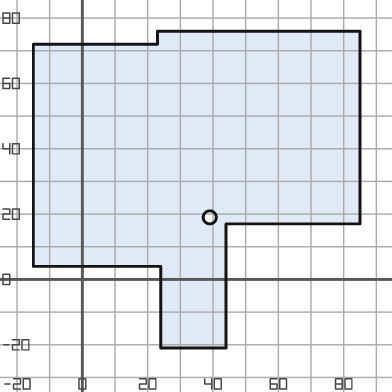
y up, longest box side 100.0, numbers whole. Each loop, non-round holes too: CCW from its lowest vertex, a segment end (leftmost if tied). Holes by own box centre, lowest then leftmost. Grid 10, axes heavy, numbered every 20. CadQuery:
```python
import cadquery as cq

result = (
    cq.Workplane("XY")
    .moveTo(24.0, -21.0)
    .lineTo(44.0, -21.0)
    .lineTo(44.0, 17.0)
    .lineTo(85.0, 17.0)
    .lineTo(85.0, 76.0)
    .lineTo(23.0, 76.0)
    .lineTo(23.0, 72.0)
    .lineTo(-15.0, 72.0)
    .lineTo(-15.0, 4.0)
    .lineTo(24.0, 4.0)
    .close()
    .moveTo(39.0, 19.0)
    .circle(2.0)
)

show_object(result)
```